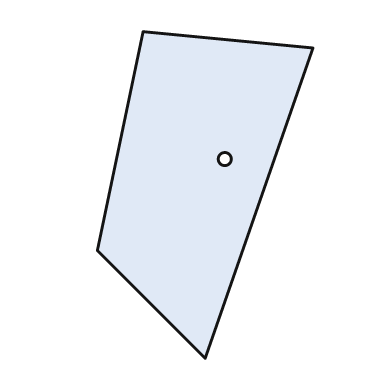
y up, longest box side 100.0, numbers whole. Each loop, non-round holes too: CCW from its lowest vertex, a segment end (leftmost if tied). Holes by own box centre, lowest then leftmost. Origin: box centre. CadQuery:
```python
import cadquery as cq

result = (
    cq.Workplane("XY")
    .moveTo(0.0, -50.0)
    .lineTo(33.0, 45.0)
    .lineTo(-19.0, 50.0)
    .lineTo(-33.0, -17.0)
    .close()
    .moveTo(6.0, 11.0)
    .circle(2.0)
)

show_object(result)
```